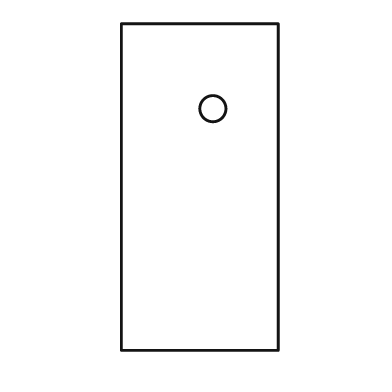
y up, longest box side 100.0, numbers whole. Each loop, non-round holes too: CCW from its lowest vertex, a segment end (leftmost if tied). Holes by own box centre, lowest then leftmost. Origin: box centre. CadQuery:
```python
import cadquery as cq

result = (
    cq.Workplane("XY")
    .moveTo(-24.0, -50.0)
    .lineTo(24.0, -50.0)
    .lineTo(24.0, 50.0)
    .lineTo(-24.0, 50.0)
    .close()
    .moveTo(4.0, 24.0)
    .circle(4.0)
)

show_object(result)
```